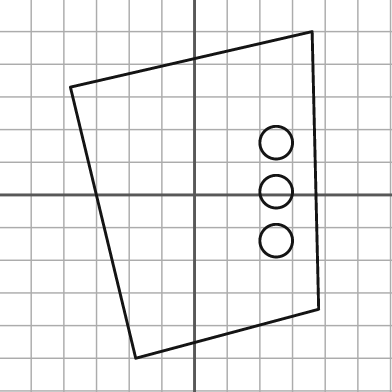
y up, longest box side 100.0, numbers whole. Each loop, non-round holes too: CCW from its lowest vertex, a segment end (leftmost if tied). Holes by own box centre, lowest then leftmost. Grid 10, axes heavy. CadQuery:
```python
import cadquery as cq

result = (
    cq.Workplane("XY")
    .moveTo(-18.0, -50.0)
    .lineTo(38.0, -35.0)
    .lineTo(36.0, 50.0)
    .lineTo(-38.0, 33.0)
    .close()
    .moveTo(25.0, -14.0)
    .circle(5.0)
    .moveTo(25.0, 1.0)
    .circle(5.0)
    .moveTo(25.0, 16.0)
    .circle(5.0)
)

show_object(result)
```